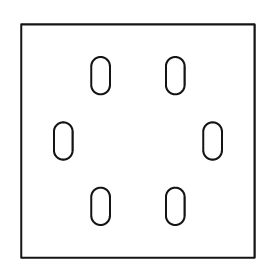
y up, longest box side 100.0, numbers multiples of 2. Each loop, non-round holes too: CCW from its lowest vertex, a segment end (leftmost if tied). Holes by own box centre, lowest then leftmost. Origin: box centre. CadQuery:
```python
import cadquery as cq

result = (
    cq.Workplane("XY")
    .moveTo(-50.0, -50.0)
    .lineTo(50.0, -50.0)
    .lineTo(50.0, 50.0)
    .lineTo(-50.0, 50.0)
    .close()
    .moveTo(-20.0, -32.0)
    .threePointArc((-16.0, -36.0), (-12.0, -32.0))
    .lineTo(-12.0, -24.0)
    .threePointArc((-16.0, -20.0), (-20.0, -24.0))
    .close()
    .moveTo(12.0, -32.0)
    .threePointArc((16.0, -36.0), (20.0, -32.0))
    .lineTo(20.0, -24.0)
    .threePointArc((16.0, -20.0), (12.0, -24.0))
    .close()
    .moveTo(-36.0, -4.0)
    .threePointArc((-32.0, -8.0), (-28.0, -4.0))
    .lineTo(-28.0, 4.0)
    .threePointArc((-32.0, 8.0), (-36.0, 4.0))
    .close()
    .moveTo(28.0, -4.0)
    .threePointArc((32.0, -8.0), (36.0, -4.0))
    .lineTo(36.0, 4.0)
    .threePointArc((32.0, 8.0), (28.0, 4.0))
    .close()
    .moveTo(-20.0, 24.0)
    .threePointArc((-16.0, 20.0), (-12.0, 24.0))
    .lineTo(-12.0, 32.0)
    .threePointArc((-16.0, 36.0), (-20.0, 32.0))
    .close()
    .moveTo(12.0, 24.0)
    .threePointArc((16.0, 20.0), (20.0, 24.0))
    .lineTo(20.0, 32.0)
    .threePointArc((16.0, 36.0), (12.0, 32.0))
    .close()
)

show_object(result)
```